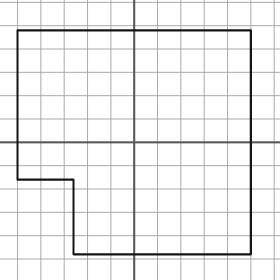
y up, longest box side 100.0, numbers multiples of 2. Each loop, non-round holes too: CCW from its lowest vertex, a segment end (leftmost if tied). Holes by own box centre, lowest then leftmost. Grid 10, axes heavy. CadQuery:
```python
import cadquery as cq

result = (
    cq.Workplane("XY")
    .moveTo(-26.0, -48.0)
    .lineTo(50.0, -48.0)
    .lineTo(50.0, 48.0)
    .lineTo(-50.0, 48.0)
    .lineTo(-50.0, -16.0)
    .lineTo(-26.0, -16.0)
    .close()
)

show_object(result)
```